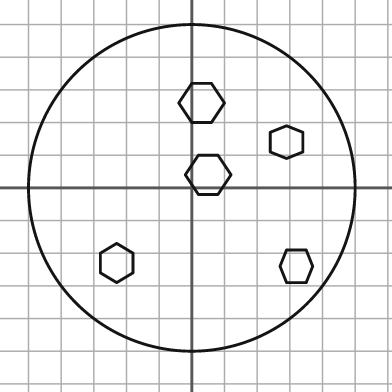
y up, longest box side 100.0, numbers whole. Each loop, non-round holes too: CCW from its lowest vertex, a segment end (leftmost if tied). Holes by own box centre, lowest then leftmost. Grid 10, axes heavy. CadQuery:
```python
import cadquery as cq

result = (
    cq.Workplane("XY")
    .moveTo(0.0, 0.0)
    .circle(50.0)
    .moveTo(29.0, -29.0)
    .lineTo(35.0, -29.0)
    .lineTo(37.0, -24.0)
    .lineTo(35.0, -19.0)
    .lineTo(29.0, -19.0)
    .lineTo(27.0, -24.0)
    .close()
    .moveTo(-23.0, -29.0)
    .lineTo(-18.0, -26.0)
    .lineTo(-18.0, -20.0)
    .lineTo(-23.0, -17.0)
    .lineTo(-28.0, -20.0)
    .lineTo(-28.0, -26.0)
    .close()
    .moveTo(2.0, -2.0)
    .lineTo(8.0, -2.0)
    .lineTo(12.0, 4.0)
    .lineTo(8.0, 10.0)
    .lineTo(2.0, 10.0)
    .lineTo(-2.0, 4.0)
    .close()
    .moveTo(29.0, 9.0)
    .lineTo(34.0, 11.0)
    .lineTo(34.0, 17.0)
    .lineTo(29.0, 19.0)
    .lineTo(24.0, 17.0)
    .lineTo(24.0, 11.0)
    .close()
    .moveTo(0.0, 20.0)
    .lineTo(6.0, 20.0)
    .lineTo(10.0, 26.0)
    .lineTo(6.0, 32.0)
    .lineTo(0.0, 32.0)
    .lineTo(-4.0, 26.0)
    .close()
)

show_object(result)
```